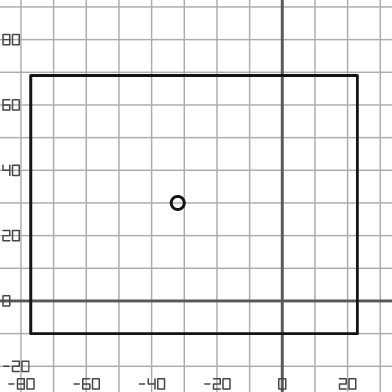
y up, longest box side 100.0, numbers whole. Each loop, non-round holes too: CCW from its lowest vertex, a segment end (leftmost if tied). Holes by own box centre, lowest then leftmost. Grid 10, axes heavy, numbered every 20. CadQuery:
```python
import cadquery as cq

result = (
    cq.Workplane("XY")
    .moveTo(-77.0, -10.0)
    .lineTo(23.0, -10.0)
    .lineTo(23.0, 69.0)
    .lineTo(-77.0, 69.0)
    .close()
    .moveTo(-32.0, 30.0)
    .circle(2.0)
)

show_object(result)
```